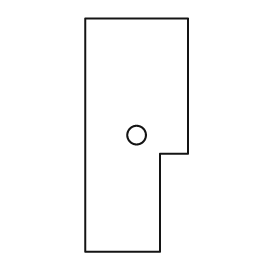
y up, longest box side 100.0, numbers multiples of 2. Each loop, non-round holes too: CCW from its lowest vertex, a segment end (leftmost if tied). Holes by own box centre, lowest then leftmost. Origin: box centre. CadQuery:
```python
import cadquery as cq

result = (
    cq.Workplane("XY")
    .moveTo(-22.0, -50.0)
    .lineTo(10.0, -50.0)
    .lineTo(10.0, -8.0)
    .lineTo(22.0, -8.0)
    .lineTo(22.0, 50.0)
    .lineTo(-22.0, 50.0)
    .close()
    .moveTo(0.0, 0.0)
    .circle(4.0)
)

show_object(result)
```